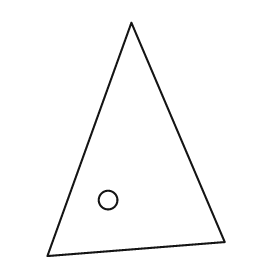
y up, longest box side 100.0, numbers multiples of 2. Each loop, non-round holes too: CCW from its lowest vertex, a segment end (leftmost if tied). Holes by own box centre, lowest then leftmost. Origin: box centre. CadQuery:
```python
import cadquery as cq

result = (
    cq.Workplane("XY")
    .moveTo(-38.0, -50.0)
    .lineTo(38.0, -44.0)
    .lineTo(-2.0, 50.0)
    .close()
    .moveTo(-12.0, -26.0)
    .circle(4.0)
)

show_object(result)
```